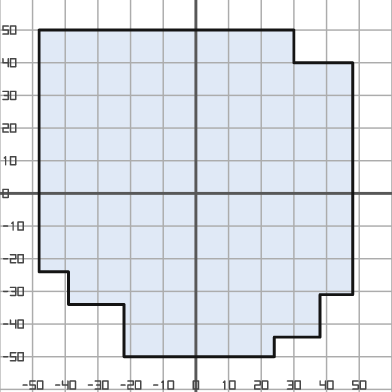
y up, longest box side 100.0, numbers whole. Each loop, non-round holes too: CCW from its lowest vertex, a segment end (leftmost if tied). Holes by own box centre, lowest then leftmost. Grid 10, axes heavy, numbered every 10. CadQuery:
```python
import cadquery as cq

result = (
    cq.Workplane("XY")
    .moveTo(-22.0, -50.0)
    .lineTo(24.0, -50.0)
    .lineTo(24.0, -44.0)
    .lineTo(38.0, -44.0)
    .lineTo(38.0, -31.0)
    .lineTo(48.0, -31.0)
    .lineTo(48.0, 40.0)
    .lineTo(30.0, 40.0)
    .lineTo(30.0, 50.0)
    .lineTo(-48.0, 50.0)
    .lineTo(-48.0, -24.0)
    .lineTo(-39.0, -24.0)
    .lineTo(-39.0, -34.0)
    .lineTo(-22.0, -34.0)
    .close()
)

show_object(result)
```